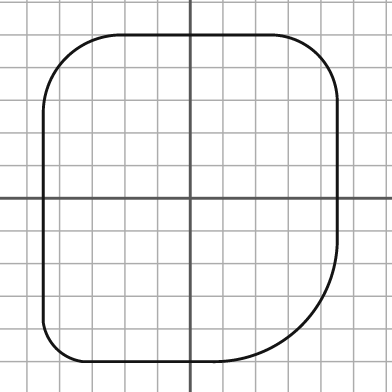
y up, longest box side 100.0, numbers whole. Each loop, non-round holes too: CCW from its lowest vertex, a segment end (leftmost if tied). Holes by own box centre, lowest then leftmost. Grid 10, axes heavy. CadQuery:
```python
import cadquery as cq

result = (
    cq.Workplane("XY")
    .moveTo(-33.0, -50.0)
    .lineTo(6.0, -50.0)
    .threePointArc((34.0, -39.0), (45.0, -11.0))
    .lineTo(45.0, 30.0)
    .threePointArc((39.0, 44.0), (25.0, 50.0))
    .lineTo(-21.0, 50.0)
    .threePointArc((-38.0, 43.0), (-45.0, 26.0))
    .lineTo(-45.0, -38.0)
    .threePointArc((-41.0, -46.0), (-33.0, -50.0))
    .close()
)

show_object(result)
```